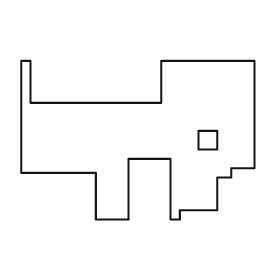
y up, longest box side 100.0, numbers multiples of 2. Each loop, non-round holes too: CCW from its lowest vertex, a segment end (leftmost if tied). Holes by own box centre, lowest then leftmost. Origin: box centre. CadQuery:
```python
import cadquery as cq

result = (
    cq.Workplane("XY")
    .moveTo(-18.0, -34.0)
    .lineTo(-4.0, -34.0)
    .lineTo(-4.0, -8.0)
    .lineTo(14.0, -8.0)
    .lineTo(14.0, -34.0)
    .lineTo(18.0, -34.0)
    .lineTo(18.0, -30.0)
    .lineTo(34.0, -30.0)
    .lineTo(34.0, -16.0)
    .lineTo(40.0, -16.0)
    .lineTo(40.0, -12.0)
    .lineTo(50.0, -12.0)
    .lineTo(50.0, 34.0)
    .lineTo(10.0, 34.0)
    .lineTo(10.0, 16.0)
    .lineTo(-46.0, 16.0)
    .lineTo(-46.0, 34.0)
    .lineTo(-50.0, 34.0)
    .lineTo(-50.0, -14.0)
    .lineTo(-18.0, -14.0)
    .close()
    .moveTo(26.0, -4.0)
    .lineTo(34.0, -4.0)
    .lineTo(34.0, 4.0)
    .lineTo(26.0, 4.0)
    .close()
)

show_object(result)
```